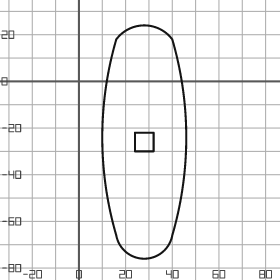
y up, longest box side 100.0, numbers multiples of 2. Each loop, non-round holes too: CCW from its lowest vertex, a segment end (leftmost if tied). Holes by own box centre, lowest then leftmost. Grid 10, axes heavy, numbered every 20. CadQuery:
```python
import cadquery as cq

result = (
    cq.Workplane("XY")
    .moveTo(16.0, -66.0)
    .threePointArc((28.0, -76.0), (40.0, -66.0))
    .threePointArc((46.0, -24.0), (40.0, 18.0))
    .threePointArc((28.0, 24.0), (16.0, 18.0))
    .threePointArc((10.0, -24.0), (16.0, -66.0))
    .close()
    .moveTo(24.0, -30.0)
    .lineTo(32.0, -30.0)
    .lineTo(32.0, -22.0)
    .lineTo(24.0, -22.0)
    .close()
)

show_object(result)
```